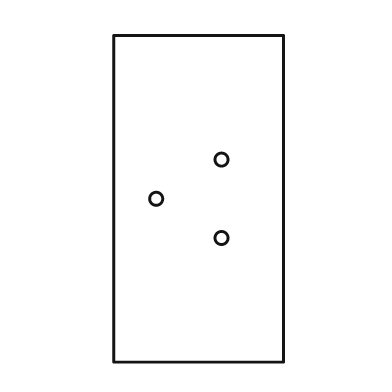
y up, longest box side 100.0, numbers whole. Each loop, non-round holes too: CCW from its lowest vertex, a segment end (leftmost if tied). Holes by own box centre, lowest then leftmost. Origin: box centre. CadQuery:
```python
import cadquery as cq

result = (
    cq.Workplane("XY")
    .moveTo(-26.0, -50.0)
    .lineTo(26.0, -50.0)
    .lineTo(26.0, 50.0)
    .lineTo(-26.0, 50.0)
    .close()
    .moveTo(7.0, -12.0)
    .circle(2.0)
    .moveTo(-13.0, 0.0)
    .circle(2.0)
    .moveTo(7.0, 12.0)
    .circle(2.0)
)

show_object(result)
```